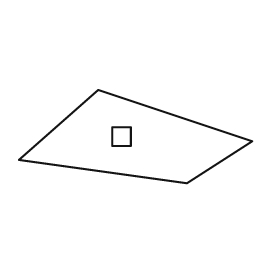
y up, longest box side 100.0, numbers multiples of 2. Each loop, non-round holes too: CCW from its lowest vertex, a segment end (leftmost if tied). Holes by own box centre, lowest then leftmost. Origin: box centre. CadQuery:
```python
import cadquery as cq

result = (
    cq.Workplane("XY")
    .moveTo(22.0, -20.0)
    .lineTo(50.0, -2.0)
    .lineTo(-16.0, 20.0)
    .lineTo(-50.0, -10.0)
    .close()
    .moveTo(-10.0, -4.0)
    .lineTo(-2.0, -4.0)
    .lineTo(-2.0, 4.0)
    .lineTo(-10.0, 4.0)
    .close()
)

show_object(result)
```